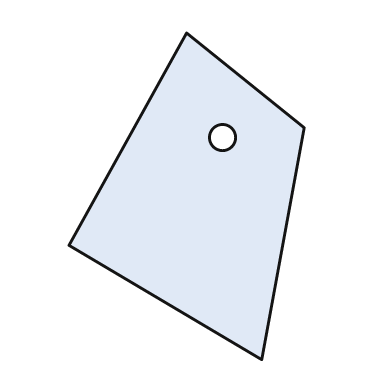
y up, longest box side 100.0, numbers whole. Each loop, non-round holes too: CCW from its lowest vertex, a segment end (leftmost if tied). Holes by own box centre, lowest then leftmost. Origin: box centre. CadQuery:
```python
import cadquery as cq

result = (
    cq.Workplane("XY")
    .moveTo(23.0, -50.0)
    .lineTo(36.0, 21.0)
    .lineTo(0.0, 50.0)
    .lineTo(-36.0, -15.0)
    .close()
    .moveTo(11.0, 18.0)
    .circle(4.0)
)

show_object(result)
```